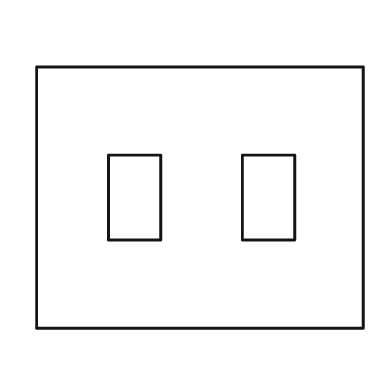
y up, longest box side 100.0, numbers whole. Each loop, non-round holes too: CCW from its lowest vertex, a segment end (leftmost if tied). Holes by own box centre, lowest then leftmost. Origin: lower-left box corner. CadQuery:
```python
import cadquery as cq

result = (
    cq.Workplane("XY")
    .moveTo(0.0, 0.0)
    .lineTo(100.0, 0.0)
    .lineTo(100.0, 80.0)
    .lineTo(0.0, 80.0)
    .close()
    .moveTo(22.0, 27.0)
    .lineTo(38.0, 27.0)
    .lineTo(38.0, 53.0)
    .lineTo(22.0, 53.0)
    .close()
    .moveTo(63.0, 27.0)
    .lineTo(79.0, 27.0)
    .lineTo(79.0, 53.0)
    .lineTo(63.0, 53.0)
    .close()
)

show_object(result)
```